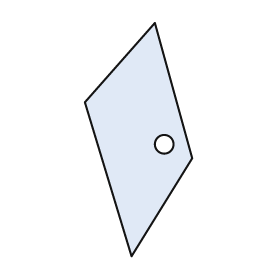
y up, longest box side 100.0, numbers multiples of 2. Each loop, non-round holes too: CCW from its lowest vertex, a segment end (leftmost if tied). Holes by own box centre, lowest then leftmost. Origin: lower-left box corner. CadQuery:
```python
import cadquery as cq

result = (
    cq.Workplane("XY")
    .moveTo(20.0, 0.0)
    .lineTo(46.0, 42.0)
    .lineTo(30.0, 100.0)
    .lineTo(0.0, 66.0)
    .close()
    .moveTo(34.0, 48.0)
    .circle(4.0)
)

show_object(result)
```